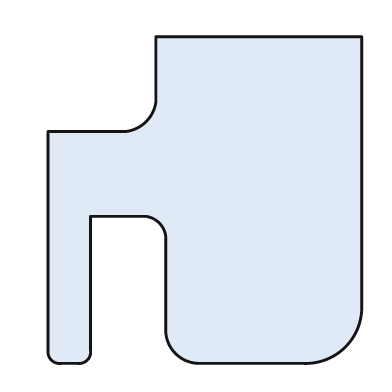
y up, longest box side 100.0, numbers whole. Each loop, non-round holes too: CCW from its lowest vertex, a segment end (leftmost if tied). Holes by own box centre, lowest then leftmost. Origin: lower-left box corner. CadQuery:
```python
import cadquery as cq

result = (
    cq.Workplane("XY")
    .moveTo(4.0, 0.0)
    .lineTo(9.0, 0.0)
    .threePointArc((12.0, 1.0), (13.0, 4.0))
    .lineTo(13.0, 45.0)
    .lineTo(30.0, 45.0)
    .threePointArc((34.0, 43.0), (36.0, 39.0))
    .lineTo(36.0, 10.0)
    .threePointArc((39.0, 3.0), (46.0, 0.0))
    .lineTo(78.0, 0.0)
    .threePointArc((91.0, 5.0), (96.0, 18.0))
    .lineTo(96.0, 100.0)
    .lineTo(33.0, 100.0)
    .lineTo(33.0, 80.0)
    .threePointArc((30.0, 74.0), (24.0, 71.0))
    .lineTo(0.0, 71.0)
    .lineTo(0.0, 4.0)
    .threePointArc((1.0, 1.0), (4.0, 0.0))
    .close()
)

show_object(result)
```